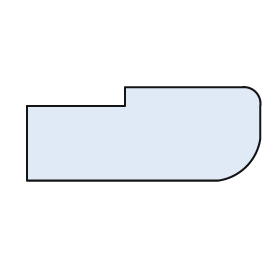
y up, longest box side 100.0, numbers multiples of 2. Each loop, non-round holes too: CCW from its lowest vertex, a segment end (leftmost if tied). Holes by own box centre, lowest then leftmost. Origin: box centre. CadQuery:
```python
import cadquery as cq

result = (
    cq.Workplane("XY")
    .moveTo(-50.0, -20.0)
    .lineTo(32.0, -20.0)
    .threePointArc((44.0, -14.0), (50.0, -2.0))
    .lineTo(50.0, 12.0)
    .threePointArc((48.0, 18.0), (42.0, 20.0))
    .lineTo(-8.0, 20.0)
    .lineTo(-8.0, 12.0)
    .lineTo(-50.0, 12.0)
    .close()
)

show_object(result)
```